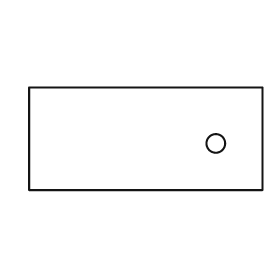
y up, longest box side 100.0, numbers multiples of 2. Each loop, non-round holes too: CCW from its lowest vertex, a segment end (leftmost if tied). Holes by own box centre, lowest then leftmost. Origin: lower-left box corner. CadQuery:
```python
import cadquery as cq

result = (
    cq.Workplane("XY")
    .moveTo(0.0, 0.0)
    .lineTo(100.0, 0.0)
    .lineTo(100.0, 44.0)
    .lineTo(0.0, 44.0)
    .close()
    .moveTo(80.0, 20.0)
    .circle(4.0)
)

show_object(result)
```